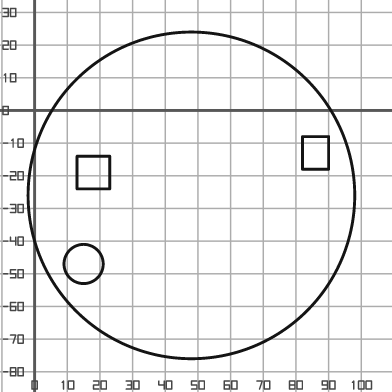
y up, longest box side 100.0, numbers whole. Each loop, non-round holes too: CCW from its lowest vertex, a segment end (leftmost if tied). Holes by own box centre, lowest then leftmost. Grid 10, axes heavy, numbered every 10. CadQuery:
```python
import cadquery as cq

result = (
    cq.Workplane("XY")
    .moveTo(48.0, -26.0)
    .circle(50.0)
    .moveTo(15.0, -47.0)
    .circle(6.0)
    .moveTo(13.0, -24.0)
    .lineTo(23.0, -24.0)
    .lineTo(23.0, -14.0)
    .lineTo(13.0, -14.0)
    .close()
    .moveTo(82.0, -18.0)
    .lineTo(90.0, -18.0)
    .lineTo(90.0, -8.0)
    .lineTo(82.0, -8.0)
    .close()
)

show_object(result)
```